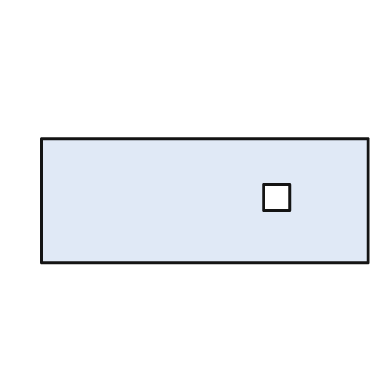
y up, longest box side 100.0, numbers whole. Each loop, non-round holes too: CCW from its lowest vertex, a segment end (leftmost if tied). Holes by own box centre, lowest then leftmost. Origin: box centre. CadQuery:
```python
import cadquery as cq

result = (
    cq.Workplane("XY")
    .moveTo(-50.0, -19.0)
    .lineTo(50.0, -19.0)
    .lineTo(50.0, 19.0)
    .lineTo(-50.0, 19.0)
    .close()
    .moveTo(18.0, -3.0)
    .lineTo(26.0, -3.0)
    .lineTo(26.0, 5.0)
    .lineTo(18.0, 5.0)
    .close()
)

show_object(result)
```